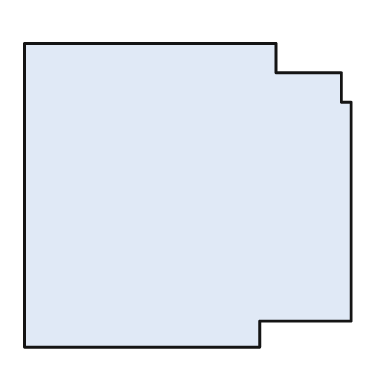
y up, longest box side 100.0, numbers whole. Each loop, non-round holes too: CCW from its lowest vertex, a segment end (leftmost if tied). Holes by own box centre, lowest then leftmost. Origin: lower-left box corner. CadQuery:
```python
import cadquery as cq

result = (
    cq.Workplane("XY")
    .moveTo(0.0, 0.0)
    .lineTo(72.0, 0.0)
    .lineTo(72.0, 8.0)
    .lineTo(100.0, 8.0)
    .lineTo(100.0, 75.0)
    .lineTo(97.0, 75.0)
    .lineTo(97.0, 84.0)
    .lineTo(77.0, 84.0)
    .lineTo(77.0, 93.0)
    .lineTo(0.0, 93.0)
    .close()
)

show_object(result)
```